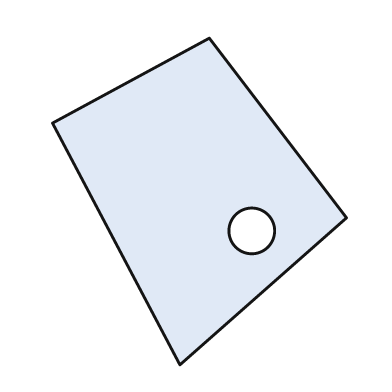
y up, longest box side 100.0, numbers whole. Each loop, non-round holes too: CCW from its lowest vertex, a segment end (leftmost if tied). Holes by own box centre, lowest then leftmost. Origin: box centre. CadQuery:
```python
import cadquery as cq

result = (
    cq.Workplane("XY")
    .moveTo(-6.0, -50.0)
    .lineTo(45.0, -5.0)
    .lineTo(3.0, 50.0)
    .lineTo(-45.0, 24.0)
    .close()
    .moveTo(16.0, -9.0)
    .circle(7.0)
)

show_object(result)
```